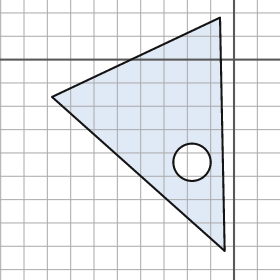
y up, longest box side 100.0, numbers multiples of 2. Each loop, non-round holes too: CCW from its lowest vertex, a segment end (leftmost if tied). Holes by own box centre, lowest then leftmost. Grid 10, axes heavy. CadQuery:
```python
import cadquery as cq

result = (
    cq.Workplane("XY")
    .moveTo(-4.0, -82.0)
    .lineTo(-6.0, 18.0)
    .lineTo(-78.0, -16.0)
    .close()
    .moveTo(-18.0, -44.0)
    .circle(8.0)
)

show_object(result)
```